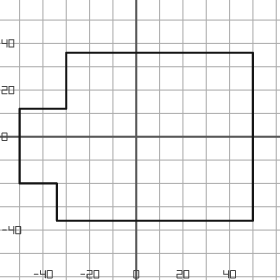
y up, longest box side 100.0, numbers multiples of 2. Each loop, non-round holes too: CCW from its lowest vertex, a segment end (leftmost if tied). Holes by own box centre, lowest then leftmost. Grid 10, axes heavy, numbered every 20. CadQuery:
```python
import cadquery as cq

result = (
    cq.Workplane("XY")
    .moveTo(-34.0, -36.0)
    .lineTo(50.0, -36.0)
    .lineTo(50.0, 36.0)
    .lineTo(-30.0, 36.0)
    .lineTo(-30.0, 12.0)
    .lineTo(-50.0, 12.0)
    .lineTo(-50.0, -20.0)
    .lineTo(-34.0, -20.0)
    .close()
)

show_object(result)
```